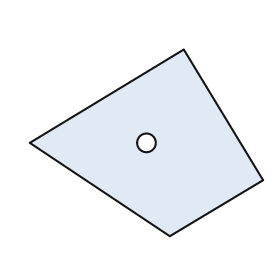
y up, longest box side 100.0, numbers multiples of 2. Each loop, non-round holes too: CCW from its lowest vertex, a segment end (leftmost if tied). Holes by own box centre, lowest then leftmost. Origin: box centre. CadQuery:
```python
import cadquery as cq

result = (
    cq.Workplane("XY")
    .moveTo(10.0, -40.0)
    .lineTo(50.0, -16.0)
    .lineTo(16.0, 40.0)
    .lineTo(-50.0, 0.0)
    .close()
    .moveTo(0.0, 0.0)
    .circle(4.0)
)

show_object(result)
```